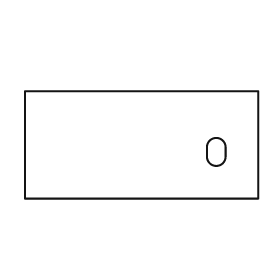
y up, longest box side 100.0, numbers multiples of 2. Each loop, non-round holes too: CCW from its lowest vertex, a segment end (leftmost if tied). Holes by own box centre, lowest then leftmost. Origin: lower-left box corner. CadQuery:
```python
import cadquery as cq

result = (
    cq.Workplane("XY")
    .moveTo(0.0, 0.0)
    .lineTo(100.0, 0.0)
    .lineTo(100.0, 46.0)
    .lineTo(0.0, 46.0)
    .close()
    .moveTo(78.0, 18.0)
    .threePointArc((82.0, 14.0), (86.0, 18.0))
    .lineTo(86.0, 22.0)
    .threePointArc((82.0, 26.0), (78.0, 22.0))
    .close()
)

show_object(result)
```